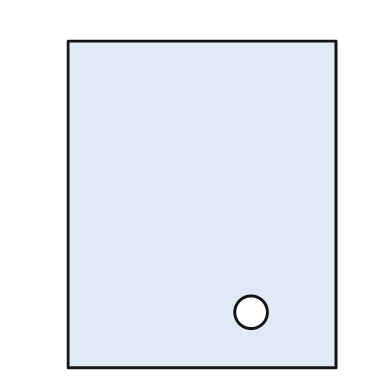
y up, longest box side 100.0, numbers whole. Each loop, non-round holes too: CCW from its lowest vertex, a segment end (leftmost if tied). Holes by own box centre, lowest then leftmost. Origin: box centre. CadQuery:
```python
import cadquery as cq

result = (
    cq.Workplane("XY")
    .moveTo(-41.0, -50.0)
    .lineTo(41.0, -50.0)
    .lineTo(41.0, 50.0)
    .lineTo(-41.0, 50.0)
    .close()
    .moveTo(15.0, -33.0)
    .circle(5.0)
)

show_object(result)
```